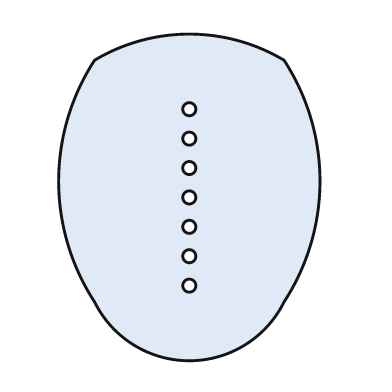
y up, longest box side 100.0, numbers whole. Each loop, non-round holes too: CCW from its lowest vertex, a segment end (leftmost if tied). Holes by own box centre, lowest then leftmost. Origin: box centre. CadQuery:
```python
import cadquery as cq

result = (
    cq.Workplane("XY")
    .moveTo(-29.0, -32.0)
    .threePointArc((0.0, -50.0), (29.0, -32.0))
    .threePointArc((40.0, 5.0), (29.0, 42.0))
    .threePointArc((0.0, 50.0), (-29.0, 42.0))
    .threePointArc((-40.0, 5.0), (-29.0, -32.0))
    .close()
    .moveTo(0.0, -27.0)
    .circle(2.0)
    .moveTo(0.0, -18.0)
    .circle(2.0)
    .moveTo(0.0, -9.0)
    .circle(2.0)
    .moveTo(0.0, 0.0)
    .circle(2.0)
    .moveTo(0.0, 9.0)
    .circle(2.0)
    .moveTo(0.0, 18.0)
    .circle(2.0)
    .moveTo(0.0, 27.0)
    .circle(2.0)
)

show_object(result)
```